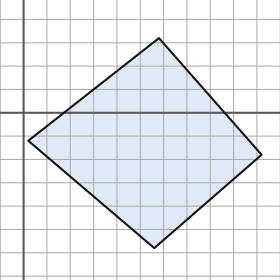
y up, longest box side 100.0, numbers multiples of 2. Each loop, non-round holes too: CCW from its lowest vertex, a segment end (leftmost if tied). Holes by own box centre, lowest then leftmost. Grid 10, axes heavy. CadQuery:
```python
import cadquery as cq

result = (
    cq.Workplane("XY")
    .moveTo(56.0, -58.0)
    .lineTo(102.0, -18.0)
    .lineTo(58.0, 32.0)
    .lineTo(2.0, -12.0)
    .close()
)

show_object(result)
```